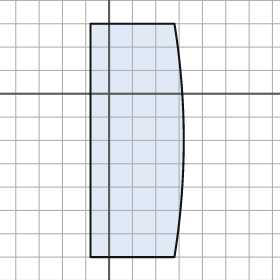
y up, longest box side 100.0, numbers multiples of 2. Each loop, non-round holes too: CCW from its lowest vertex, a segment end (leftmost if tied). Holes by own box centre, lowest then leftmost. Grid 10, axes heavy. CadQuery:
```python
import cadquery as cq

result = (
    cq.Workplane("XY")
    .moveTo(-8.0, -70.0)
    .lineTo(28.0, -70.0)
    .threePointArc((32.0, -20.0), (28.0, 30.0))
    .lineTo(-8.0, 30.0)
    .close()
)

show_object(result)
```